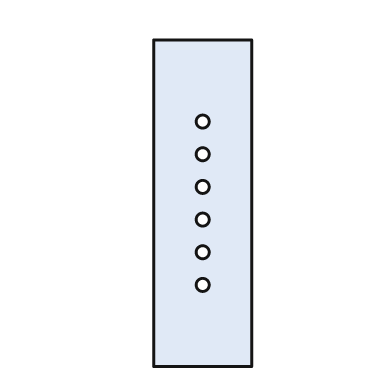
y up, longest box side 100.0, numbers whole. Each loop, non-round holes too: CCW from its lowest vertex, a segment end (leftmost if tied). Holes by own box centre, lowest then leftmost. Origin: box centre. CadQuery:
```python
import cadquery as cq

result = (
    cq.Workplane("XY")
    .moveTo(-15.0, -50.0)
    .lineTo(15.0, -50.0)
    .lineTo(15.0, 50.0)
    .lineTo(-15.0, 50.0)
    .close()
    .moveTo(0.0, -25.0)
    .circle(2.0)
    .moveTo(0.0, -15.0)
    .circle(2.0)
    .moveTo(0.0, -5.0)
    .circle(2.0)
    .moveTo(0.0, 5.0)
    .circle(2.0)
    .moveTo(0.0, 15.0)
    .circle(2.0)
    .moveTo(0.0, 25.0)
    .circle(2.0)
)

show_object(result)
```